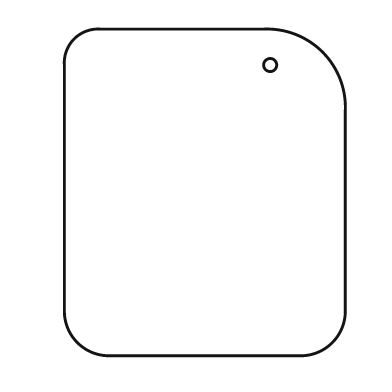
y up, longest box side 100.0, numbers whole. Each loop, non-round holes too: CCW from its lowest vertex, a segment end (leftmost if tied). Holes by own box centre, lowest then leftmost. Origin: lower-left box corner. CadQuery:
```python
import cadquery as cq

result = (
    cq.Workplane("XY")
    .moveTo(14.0, 0.0)
    .lineTo(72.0, 0.0)
    .threePointArc((82.0, 4.0), (86.0, 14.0))
    .lineTo(86.0, 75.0)
    .threePointArc((79.0, 93.0), (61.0, 100.0))
    .lineTo(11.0, 100.0)
    .threePointArc((3.0, 97.0), (0.0, 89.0))
    .lineTo(0.0, 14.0)
    .threePointArc((4.0, 4.0), (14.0, 0.0))
    .close()
    .moveTo(63.0, 89.0)
    .circle(2.0)
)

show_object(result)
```